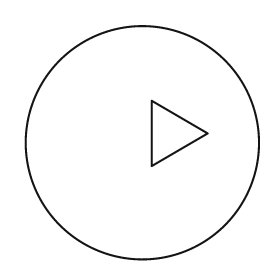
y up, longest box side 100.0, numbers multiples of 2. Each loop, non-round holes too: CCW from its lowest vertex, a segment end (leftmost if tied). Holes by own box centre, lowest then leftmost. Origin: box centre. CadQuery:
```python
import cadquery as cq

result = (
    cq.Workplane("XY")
    .moveTo(0.0, 0.0)
    .circle(50.0)
    .moveTo(4.0, -10.0)
    .lineTo(28.0, 4.0)
    .lineTo(4.0, 18.0)
    .close()
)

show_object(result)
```